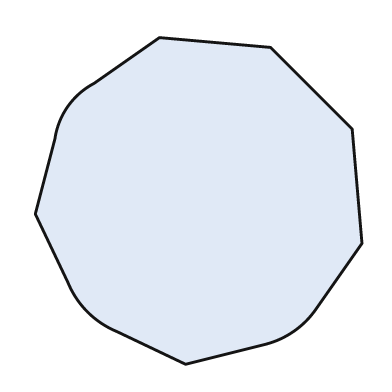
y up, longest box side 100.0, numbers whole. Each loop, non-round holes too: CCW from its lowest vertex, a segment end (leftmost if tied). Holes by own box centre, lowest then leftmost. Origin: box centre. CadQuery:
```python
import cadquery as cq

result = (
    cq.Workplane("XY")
    .moveTo(-4.0, -50.0)
    .lineTo(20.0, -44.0)
    .threePointArc((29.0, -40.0), (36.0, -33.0))
    .lineTo(50.0, -13.0)
    .lineTo(47.0, 22.0)
    .lineTo(22.0, 47.0)
    .lineTo(-12.0, 50.0)
    .lineTo(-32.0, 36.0)
    .threePointArc((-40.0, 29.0), (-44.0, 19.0))
    .lineTo(-50.0, -4.0)
    .lineTo(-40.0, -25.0)
    .threePointArc((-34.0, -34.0), (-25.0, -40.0))
    .close()
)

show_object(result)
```